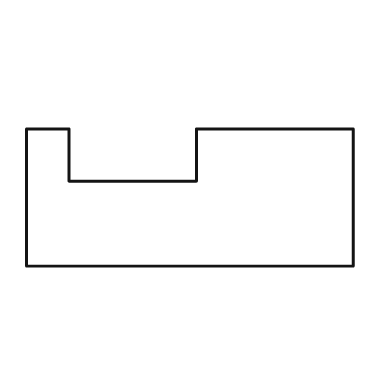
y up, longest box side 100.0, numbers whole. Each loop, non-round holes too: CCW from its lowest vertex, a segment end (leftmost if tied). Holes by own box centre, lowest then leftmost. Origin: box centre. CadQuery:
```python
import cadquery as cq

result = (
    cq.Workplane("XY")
    .moveTo(-50.0, -21.0)
    .lineTo(50.0, -21.0)
    .lineTo(50.0, 21.0)
    .lineTo(2.0, 21.0)
    .lineTo(2.0, 5.0)
    .lineTo(-37.0, 5.0)
    .lineTo(-37.0, 21.0)
    .lineTo(-50.0, 21.0)
    .close()
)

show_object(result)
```